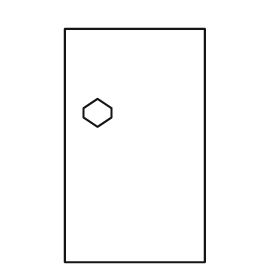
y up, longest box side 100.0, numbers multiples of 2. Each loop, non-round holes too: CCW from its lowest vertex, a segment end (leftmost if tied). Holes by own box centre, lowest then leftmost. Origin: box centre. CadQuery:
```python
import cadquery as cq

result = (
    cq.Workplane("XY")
    .moveTo(-30.0, -50.0)
    .lineTo(30.0, -50.0)
    .lineTo(30.0, 50.0)
    .lineTo(-30.0, 50.0)
    .close()
    .moveTo(-16.0, 8.0)
    .lineTo(-10.0, 12.0)
    .lineTo(-10.0, 16.0)
    .lineTo(-16.0, 20.0)
    .lineTo(-22.0, 16.0)
    .lineTo(-22.0, 12.0)
    .close()
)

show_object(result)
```